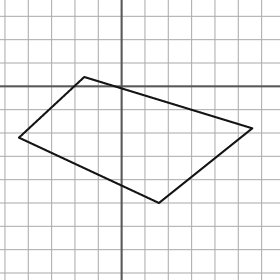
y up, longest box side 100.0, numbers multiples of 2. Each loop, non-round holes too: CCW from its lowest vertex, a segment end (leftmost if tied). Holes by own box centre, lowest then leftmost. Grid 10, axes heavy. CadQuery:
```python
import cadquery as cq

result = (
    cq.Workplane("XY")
    .moveTo(16.0, -50.0)
    .lineTo(56.0, -18.0)
    .lineTo(-16.0, 4.0)
    .lineTo(-44.0, -22.0)
    .close()
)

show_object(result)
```